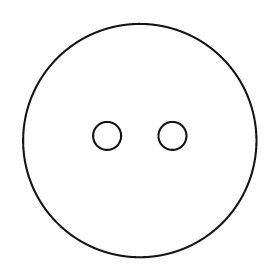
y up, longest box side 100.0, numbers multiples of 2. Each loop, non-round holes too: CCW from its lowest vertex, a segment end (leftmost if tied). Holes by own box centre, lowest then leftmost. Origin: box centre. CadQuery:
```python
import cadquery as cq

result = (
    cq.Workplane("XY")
    .moveTo(0.0, 0.0)
    .circle(50.0)
    .moveTo(-14.0, 2.0)
    .circle(6.0)
    .moveTo(14.0, 2.0)
    .circle(6.0)
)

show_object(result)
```